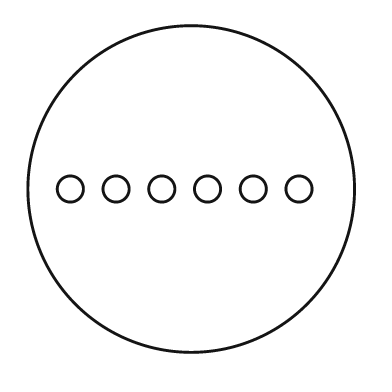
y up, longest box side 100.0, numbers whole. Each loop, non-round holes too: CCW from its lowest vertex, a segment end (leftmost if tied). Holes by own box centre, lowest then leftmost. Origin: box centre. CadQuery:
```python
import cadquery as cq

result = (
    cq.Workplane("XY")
    .moveTo(0.0, 0.0)
    .circle(50.0)
    .moveTo(-37.0, 0.0)
    .circle(4.0)
    .moveTo(-23.0, 0.0)
    .circle(4.0)
    .moveTo(-9.0, 0.0)
    .circle(4.0)
    .moveTo(5.0, 0.0)
    .circle(4.0)
    .moveTo(19.0, 0.0)
    .circle(4.0)
    .moveTo(33.0, 0.0)
    .circle(4.0)
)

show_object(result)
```